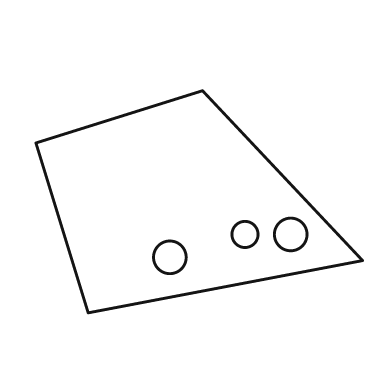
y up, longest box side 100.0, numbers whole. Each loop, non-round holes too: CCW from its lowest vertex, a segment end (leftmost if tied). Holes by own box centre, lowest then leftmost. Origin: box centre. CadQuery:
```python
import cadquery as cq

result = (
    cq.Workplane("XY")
    .moveTo(-34.0, -34.0)
    .lineTo(50.0, -18.0)
    .lineTo(1.0, 34.0)
    .lineTo(-50.0, 18.0)
    .close()
    .moveTo(-9.0, -17.0)
    .circle(5.0)
    .moveTo(14.0, -10.0)
    .circle(4.0)
    .moveTo(28.0, -10.0)
    .circle(5.0)
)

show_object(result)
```